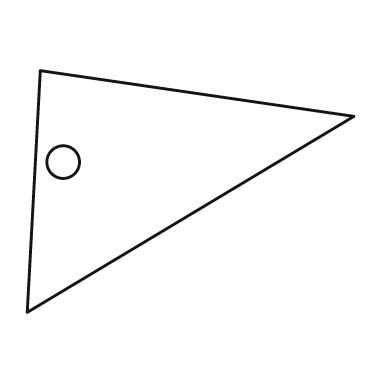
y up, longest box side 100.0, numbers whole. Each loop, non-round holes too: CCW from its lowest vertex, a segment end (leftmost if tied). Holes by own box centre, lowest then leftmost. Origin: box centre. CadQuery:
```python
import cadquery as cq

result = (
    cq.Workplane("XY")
    .moveTo(-50.0, -37.0)
    .lineTo(50.0, 23.0)
    .lineTo(-46.0, 37.0)
    .close()
    .moveTo(-39.0, 9.0)
    .circle(5.0)
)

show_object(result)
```